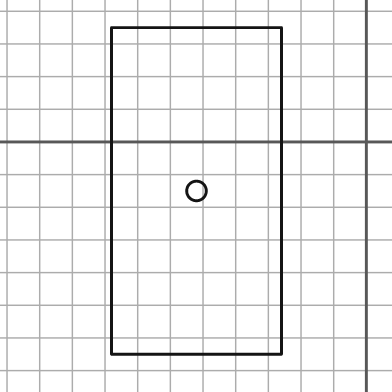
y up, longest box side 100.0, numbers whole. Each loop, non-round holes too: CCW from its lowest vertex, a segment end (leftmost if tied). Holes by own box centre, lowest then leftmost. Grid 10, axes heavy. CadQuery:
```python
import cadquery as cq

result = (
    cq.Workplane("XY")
    .moveTo(-78.0, -65.0)
    .lineTo(-26.0, -65.0)
    .lineTo(-26.0, 35.0)
    .lineTo(-78.0, 35.0)
    .close()
    .moveTo(-52.0, -15.0)
    .circle(3.0)
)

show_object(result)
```